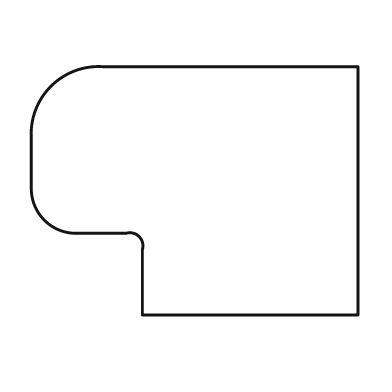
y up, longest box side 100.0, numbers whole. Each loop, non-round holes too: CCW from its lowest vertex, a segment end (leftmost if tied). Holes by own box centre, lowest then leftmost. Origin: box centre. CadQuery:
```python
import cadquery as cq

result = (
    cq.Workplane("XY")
    .moveTo(-16.0, -38.0)
    .lineTo(50.0, -38.0)
    .lineTo(50.0, 38.0)
    .lineTo(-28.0, 38.0)
    .threePointArc((-44.0, 32.0), (-50.0, 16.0))
    .lineTo(-50.0, 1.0)
    .threePointArc((-46.0, -9.0), (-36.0, -13.0))
    .lineTo(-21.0, -13.0)
    .threePointArc((-17.0, -14.0), (-16.0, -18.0))
    .close()
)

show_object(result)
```